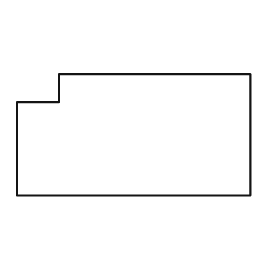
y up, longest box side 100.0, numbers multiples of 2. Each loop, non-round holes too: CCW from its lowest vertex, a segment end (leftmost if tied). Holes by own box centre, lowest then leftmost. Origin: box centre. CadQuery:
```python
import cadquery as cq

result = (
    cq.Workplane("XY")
    .moveTo(-50.0, -26.0)
    .lineTo(50.0, -26.0)
    .lineTo(50.0, 26.0)
    .lineTo(-32.0, 26.0)
    .lineTo(-32.0, 14.0)
    .lineTo(-50.0, 14.0)
    .close()
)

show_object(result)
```